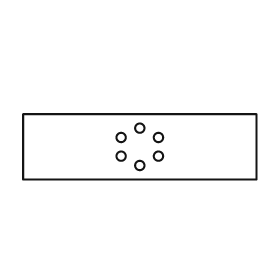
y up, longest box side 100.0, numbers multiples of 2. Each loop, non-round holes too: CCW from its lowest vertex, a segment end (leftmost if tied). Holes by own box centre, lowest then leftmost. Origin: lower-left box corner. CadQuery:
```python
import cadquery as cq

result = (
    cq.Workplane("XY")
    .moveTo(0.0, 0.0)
    .lineTo(100.0, 0.0)
    .lineTo(100.0, 28.0)
    .lineTo(0.0, 28.0)
    .close()
    .moveTo(50.0, 6.0)
    .circle(2.0)
    .moveTo(42.0, 10.0)
    .circle(2.0)
    .moveTo(58.0, 10.0)
    .circle(2.0)
    .moveTo(42.0, 18.0)
    .circle(2.0)
    .moveTo(58.0, 18.0)
    .circle(2.0)
    .moveTo(50.0, 22.0)
    .circle(2.0)
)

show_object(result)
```